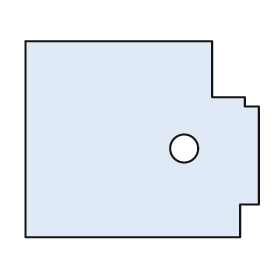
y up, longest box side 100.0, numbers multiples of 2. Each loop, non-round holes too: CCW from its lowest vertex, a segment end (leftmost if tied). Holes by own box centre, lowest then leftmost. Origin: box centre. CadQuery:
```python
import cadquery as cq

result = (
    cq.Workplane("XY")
    .moveTo(-50.0, -42.0)
    .lineTo(42.0, -42.0)
    .lineTo(42.0, -28.0)
    .lineTo(50.0, -28.0)
    .lineTo(50.0, 14.0)
    .lineTo(44.0, 14.0)
    .lineTo(44.0, 18.0)
    .lineTo(30.0, 18.0)
    .lineTo(30.0, 42.0)
    .lineTo(-50.0, 42.0)
    .close()
    .moveTo(18.0, -4.0)
    .circle(6.0)
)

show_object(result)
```